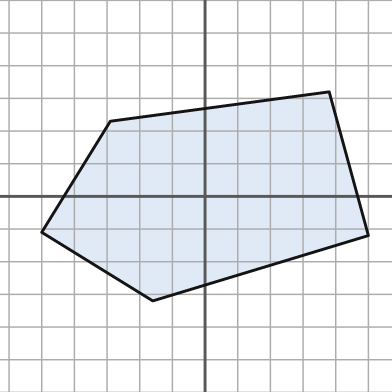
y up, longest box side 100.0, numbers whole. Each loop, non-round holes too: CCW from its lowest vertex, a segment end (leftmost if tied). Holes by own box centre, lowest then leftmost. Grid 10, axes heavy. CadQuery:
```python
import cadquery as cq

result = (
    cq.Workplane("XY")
    .moveTo(-16.0, -32.0)
    .lineTo(50.0, -12.0)
    .lineTo(38.0, 32.0)
    .lineTo(-29.0, 23.0)
    .lineTo(-50.0, -11.0)
    .close()
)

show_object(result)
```